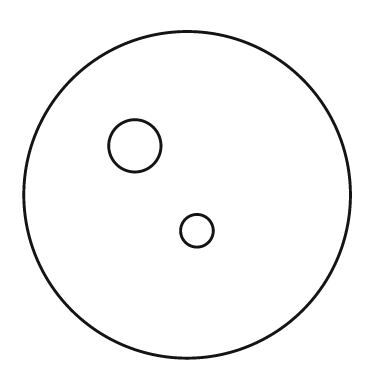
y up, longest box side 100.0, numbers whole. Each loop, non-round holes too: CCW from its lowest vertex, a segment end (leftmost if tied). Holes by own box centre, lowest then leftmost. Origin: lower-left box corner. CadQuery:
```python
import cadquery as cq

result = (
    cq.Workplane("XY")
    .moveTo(50.0, 50.0)
    .circle(50.0)
    .moveTo(53.0, 39.0)
    .circle(5.0)
    .moveTo(34.0, 65.0)
    .circle(8.0)
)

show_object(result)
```